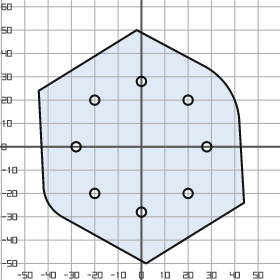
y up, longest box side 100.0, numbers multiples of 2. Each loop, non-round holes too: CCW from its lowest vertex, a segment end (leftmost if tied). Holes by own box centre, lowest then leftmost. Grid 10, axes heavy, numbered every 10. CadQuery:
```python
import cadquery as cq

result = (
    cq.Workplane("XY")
    .moveTo(2.0, -50.0)
    .lineTo(44.0, -24.0)
    .lineTo(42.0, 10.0)
    .threePointArc((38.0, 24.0), (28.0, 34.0))
    .lineTo(-2.0, 50.0)
    .lineTo(-44.0, 24.0)
    .lineTo(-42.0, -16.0)
    .threePointArc((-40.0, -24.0), (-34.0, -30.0))
    .close()
    .moveTo(0.0, -28.0)
    .circle(2.0)
    .moveTo(-20.0, -20.0)
    .circle(2.0)
    .moveTo(20.0, -20.0)
    .circle(2.0)
    .moveTo(-28.0, 0.0)
    .circle(2.0)
    .moveTo(28.0, 0.0)
    .circle(2.0)
    .moveTo(-20.0, 20.0)
    .circle(2.0)
    .moveTo(20.0, 20.0)
    .circle(2.0)
    .moveTo(0.0, 28.0)
    .circle(2.0)
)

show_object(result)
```